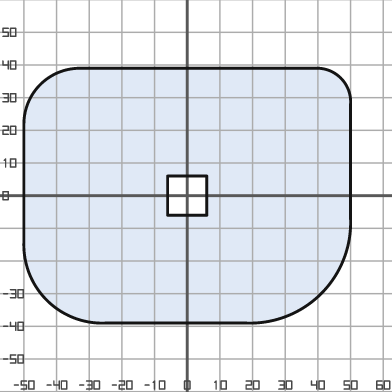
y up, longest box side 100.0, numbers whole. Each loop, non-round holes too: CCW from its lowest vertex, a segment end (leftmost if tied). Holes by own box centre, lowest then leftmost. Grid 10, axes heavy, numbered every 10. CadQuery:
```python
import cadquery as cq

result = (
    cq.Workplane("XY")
    .moveTo(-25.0, -39.0)
    .lineTo(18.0, -39.0)
    .threePointArc((41.0, -30.0), (50.0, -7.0))
    .lineTo(50.0, 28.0)
    .threePointArc((47.0, 36.0), (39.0, 39.0))
    .lineTo(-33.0, 39.0)
    .threePointArc((-45.0, 34.0), (-50.0, 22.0))
    .lineTo(-50.0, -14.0)
    .threePointArc((-43.0, -32.0), (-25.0, -39.0))
    .close()
    .moveTo(-6.0, -6.0)
    .lineTo(6.0, -6.0)
    .lineTo(6.0, 6.0)
    .lineTo(-6.0, 6.0)
    .close()
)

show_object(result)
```